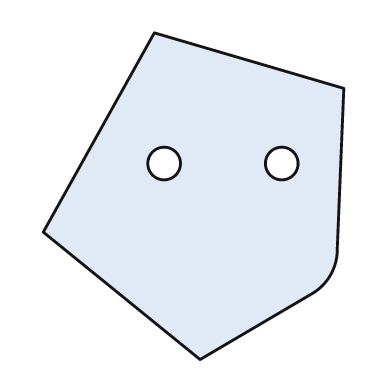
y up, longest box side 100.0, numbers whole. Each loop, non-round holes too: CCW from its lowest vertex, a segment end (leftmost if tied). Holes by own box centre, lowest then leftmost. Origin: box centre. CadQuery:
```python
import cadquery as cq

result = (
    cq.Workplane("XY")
    .moveTo(2.0, -50.0)
    .lineTo(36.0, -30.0)
    .threePointArc((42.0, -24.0), (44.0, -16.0))
    .lineTo(46.0, 33.0)
    .lineTo(-12.0, 50.0)
    .lineTo(-46.0, -11.0)
    .close()
    .moveTo(-9.0, 10.0)
    .circle(5.0)
    .moveTo(27.0, 10.0)
    .circle(5.0)
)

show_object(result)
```